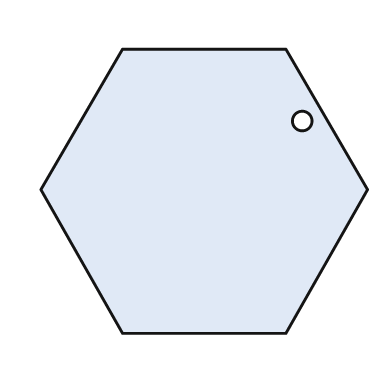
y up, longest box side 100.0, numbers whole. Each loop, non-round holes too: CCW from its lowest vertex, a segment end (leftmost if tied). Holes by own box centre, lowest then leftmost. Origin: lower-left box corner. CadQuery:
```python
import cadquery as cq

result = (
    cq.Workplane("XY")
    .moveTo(25.0, 0.0)
    .lineTo(75.0, 0.0)
    .lineTo(100.0, 44.0)
    .lineTo(75.0, 87.0)
    .lineTo(25.0, 87.0)
    .lineTo(0.0, 44.0)
    .close()
    .moveTo(80.0, 65.0)
    .circle(3.0)
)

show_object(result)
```